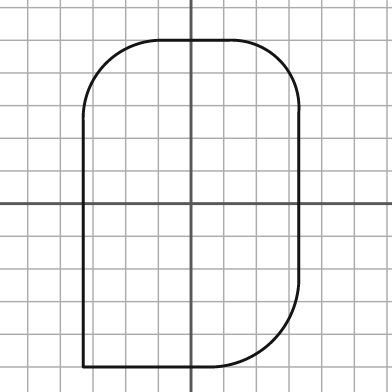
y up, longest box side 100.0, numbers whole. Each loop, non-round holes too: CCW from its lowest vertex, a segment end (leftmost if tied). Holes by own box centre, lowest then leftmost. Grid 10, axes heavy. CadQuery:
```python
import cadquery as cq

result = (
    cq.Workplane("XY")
    .moveTo(-33.0, -50.0)
    .lineTo(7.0, -50.0)
    .threePointArc((25.0, -42.0), (33.0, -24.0))
    .lineTo(33.0, 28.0)
    .threePointArc((27.0, 44.0), (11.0, 50.0))
    .lineTo(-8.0, 50.0)
    .threePointArc((-26.0, 43.0), (-33.0, 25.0))
    .close()
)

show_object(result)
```